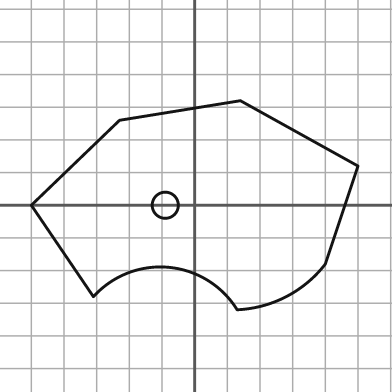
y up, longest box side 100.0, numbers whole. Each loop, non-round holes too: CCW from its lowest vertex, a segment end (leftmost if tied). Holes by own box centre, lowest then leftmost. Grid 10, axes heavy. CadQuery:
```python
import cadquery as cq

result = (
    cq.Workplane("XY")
    .moveTo(13.0, -32.0)
    .threePointArc((28.0, -28.0), (40.0, -18.0))
    .lineTo(50.0, 12.0)
    .lineTo(14.0, 32.0)
    .lineTo(-23.0, 26.0)
    .lineTo(-50.0, 0.0)
    .lineTo(-31.0, -28.0)
    .threePointArc((-8.0, -19.0), (13.0, -32.0))
    .close()
    .moveTo(-9.0, 0.0)
    .circle(4.0)
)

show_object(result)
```